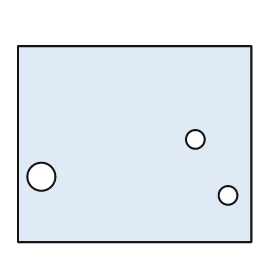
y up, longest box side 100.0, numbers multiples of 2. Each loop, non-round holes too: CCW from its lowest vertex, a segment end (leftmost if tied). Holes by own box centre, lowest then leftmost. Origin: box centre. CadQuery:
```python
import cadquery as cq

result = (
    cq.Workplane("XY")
    .moveTo(-50.0, -42.0)
    .lineTo(50.0, -42.0)
    .lineTo(50.0, 42.0)
    .lineTo(-50.0, 42.0)
    .close()
    .moveTo(40.0, -22.0)
    .circle(4.0)
    .moveTo(-40.0, -14.0)
    .circle(6.0)
    .moveTo(26.0, 2.0)
    .circle(4.0)
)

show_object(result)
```